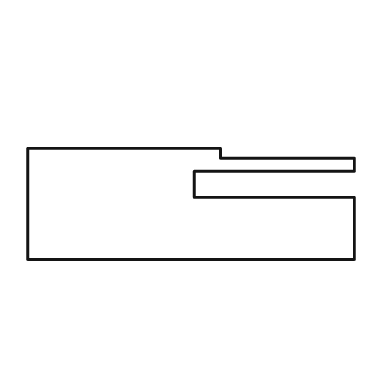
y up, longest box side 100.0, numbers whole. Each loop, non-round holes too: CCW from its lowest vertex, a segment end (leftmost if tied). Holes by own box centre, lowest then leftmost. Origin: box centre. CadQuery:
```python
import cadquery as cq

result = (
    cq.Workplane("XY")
    .moveTo(-50.0, -17.0)
    .lineTo(50.0, -17.0)
    .lineTo(50.0, 2.0)
    .lineTo(1.0, 2.0)
    .lineTo(1.0, 10.0)
    .lineTo(50.0, 10.0)
    .lineTo(50.0, 14.0)
    .lineTo(9.0, 14.0)
    .lineTo(9.0, 17.0)
    .lineTo(-50.0, 17.0)
    .close()
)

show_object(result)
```